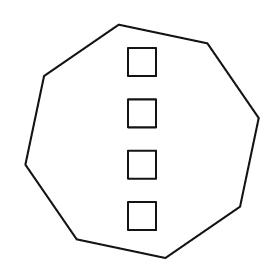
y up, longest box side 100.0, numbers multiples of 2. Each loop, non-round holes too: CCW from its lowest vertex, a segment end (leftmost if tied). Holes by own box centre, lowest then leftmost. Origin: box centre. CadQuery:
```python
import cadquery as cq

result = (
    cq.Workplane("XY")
    .moveTo(10.0, -50.0)
    .lineTo(42.0, -28.0)
    .lineTo(50.0, 10.0)
    .lineTo(28.0, 42.0)
    .lineTo(-10.0, 50.0)
    .lineTo(-42.0, 28.0)
    .lineTo(-50.0, -10.0)
    .lineTo(-28.0, -42.0)
    .close()
    .moveTo(-6.0, -38.0)
    .lineTo(6.0, -38.0)
    .lineTo(6.0, -26.0)
    .lineTo(-6.0, -26.0)
    .close()
    .moveTo(-6.0, -16.0)
    .lineTo(6.0, -16.0)
    .lineTo(6.0, -4.0)
    .lineTo(-6.0, -4.0)
    .close()
    .moveTo(-6.0, 6.0)
    .lineTo(6.0, 6.0)
    .lineTo(6.0, 18.0)
    .lineTo(-6.0, 18.0)
    .close()
    .moveTo(-6.0, 28.0)
    .lineTo(6.0, 28.0)
    .lineTo(6.0, 40.0)
    .lineTo(-6.0, 40.0)
    .close()
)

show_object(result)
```